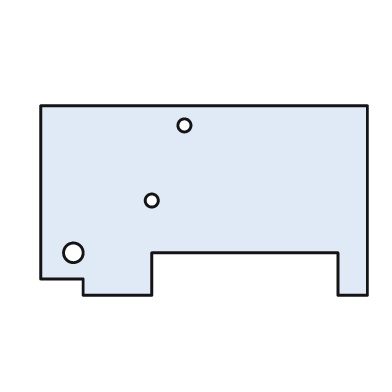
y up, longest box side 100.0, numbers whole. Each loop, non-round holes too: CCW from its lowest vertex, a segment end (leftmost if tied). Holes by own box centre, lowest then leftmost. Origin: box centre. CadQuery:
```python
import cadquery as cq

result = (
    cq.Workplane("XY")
    .moveTo(-37.0, -29.0)
    .lineTo(-16.0, -29.0)
    .lineTo(-16.0, -16.0)
    .lineTo(41.0, -16.0)
    .lineTo(41.0, -29.0)
    .lineTo(50.0, -29.0)
    .lineTo(50.0, 29.0)
    .lineTo(-50.0, 29.0)
    .lineTo(-50.0, -24.0)
    .lineTo(-37.0, -24.0)
    .close()
    .moveTo(-40.0, -16.0)
    .circle(3.0)
    .moveTo(-16.0, 0.0)
    .circle(2.0)
    .moveTo(-6.0, 23.0)
    .circle(2.0)
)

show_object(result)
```